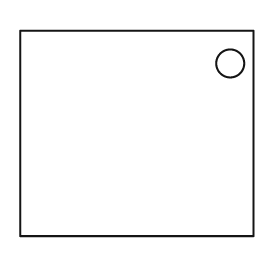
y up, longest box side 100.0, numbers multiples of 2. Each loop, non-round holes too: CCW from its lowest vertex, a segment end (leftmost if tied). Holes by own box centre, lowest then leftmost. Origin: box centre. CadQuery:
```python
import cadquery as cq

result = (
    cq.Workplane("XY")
    .moveTo(-50.0, -44.0)
    .lineTo(50.0, -44.0)
    .lineTo(50.0, 44.0)
    .lineTo(-50.0, 44.0)
    .close()
    .moveTo(40.0, 30.0)
    .circle(6.0)
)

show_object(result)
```